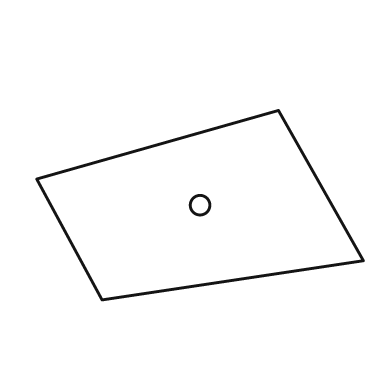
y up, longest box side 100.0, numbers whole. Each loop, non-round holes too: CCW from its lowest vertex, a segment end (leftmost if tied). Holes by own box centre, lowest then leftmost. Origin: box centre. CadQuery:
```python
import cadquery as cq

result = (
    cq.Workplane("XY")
    .moveTo(-30.0, -29.0)
    .lineTo(50.0, -17.0)
    .lineTo(24.0, 29.0)
    .lineTo(-50.0, 8.0)
    .close()
    .moveTo(0.0, 0.0)
    .circle(3.0)
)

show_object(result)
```